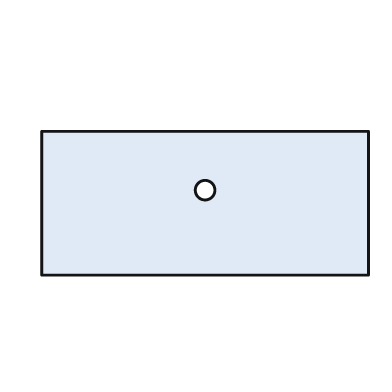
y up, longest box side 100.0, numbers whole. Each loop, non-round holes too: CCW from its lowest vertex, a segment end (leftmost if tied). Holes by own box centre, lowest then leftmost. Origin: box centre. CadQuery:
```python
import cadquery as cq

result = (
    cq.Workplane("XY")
    .moveTo(-50.0, -22.0)
    .lineTo(50.0, -22.0)
    .lineTo(50.0, 22.0)
    .lineTo(-50.0, 22.0)
    .close()
    .moveTo(0.0, 4.0)
    .circle(3.0)
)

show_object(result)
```